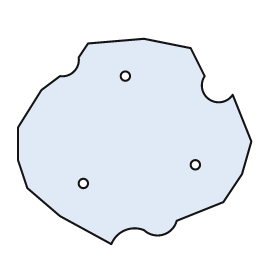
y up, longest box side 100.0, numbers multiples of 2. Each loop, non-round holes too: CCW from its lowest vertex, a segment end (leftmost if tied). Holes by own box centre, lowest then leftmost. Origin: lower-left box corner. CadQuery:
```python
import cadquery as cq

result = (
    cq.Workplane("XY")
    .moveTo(40.0, 0.0)
    .threePointArc((46.0, 6.0), (54.0, 6.0))
    .threePointArc((62.0, 4.0), (68.0, 10.0))
    .lineTo(88.0, 18.0)
    .lineTo(96.0, 30.0)
    .lineTo(100.0, 44.0)
    .lineTo(92.0, 64.0)
    .threePointArc((82.0, 62.0), (80.0, 72.0))
    .lineTo(74.0, 84.0)
    .lineTo(54.0, 88.0)
    .lineTo(30.0, 86.0)
    .lineTo(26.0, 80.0)
    .threePointArc((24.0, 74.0), (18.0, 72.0))
    .lineTo(10.0, 66.0)
    .lineTo(0.0, 50.0)
    .lineTo(0.0, 36.0)
    .lineTo(4.0, 24.0)
    .lineTo(18.0, 12.0)
    .close()
    .moveTo(28.0, 26.0)
    .circle(2.0)
    .moveTo(76.0, 34.0)
    .circle(2.0)
    .moveTo(46.0, 72.0)
    .circle(2.0)
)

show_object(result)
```